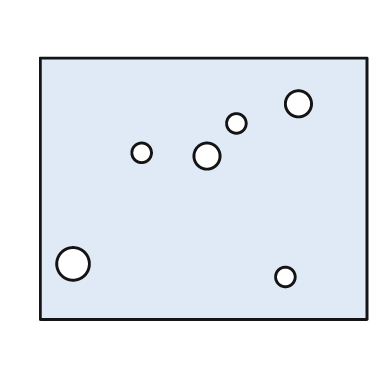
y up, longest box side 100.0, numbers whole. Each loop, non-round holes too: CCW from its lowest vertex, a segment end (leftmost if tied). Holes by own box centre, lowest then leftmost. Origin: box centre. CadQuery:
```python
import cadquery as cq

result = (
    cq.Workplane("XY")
    .moveTo(-50.0, -40.0)
    .lineTo(50.0, -40.0)
    .lineTo(50.0, 40.0)
    .lineTo(-50.0, 40.0)
    .close()
    .moveTo(25.0, -27.0)
    .circle(3.0)
    .moveTo(-40.0, -23.0)
    .circle(5.0)
    .moveTo(1.0, 10.0)
    .circle(4.0)
    .moveTo(-19.0, 11.0)
    .circle(3.0)
    .moveTo(10.0, 20.0)
    .circle(3.0)
    .moveTo(29.0, 26.0)
    .circle(4.0)
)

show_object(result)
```